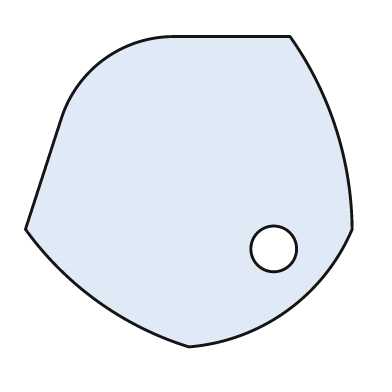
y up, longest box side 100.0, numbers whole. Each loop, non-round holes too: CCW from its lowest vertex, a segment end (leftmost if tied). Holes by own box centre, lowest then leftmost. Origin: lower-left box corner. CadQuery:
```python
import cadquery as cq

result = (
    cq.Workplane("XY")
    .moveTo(50.0, 0.0)
    .threePointArc((80.0, 11.0), (100.0, 36.0))
    .threePointArc((95.0, 67.0), (81.0, 95.0))
    .lineTo(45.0, 95.0)
    .threePointArc((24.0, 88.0), (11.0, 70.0))
    .lineTo(0.0, 36.0)
    .threePointArc((22.0, 14.0), (50.0, 0.0))
    .close()
    .moveTo(76.0, 30.0)
    .circle(7.0)
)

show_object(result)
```